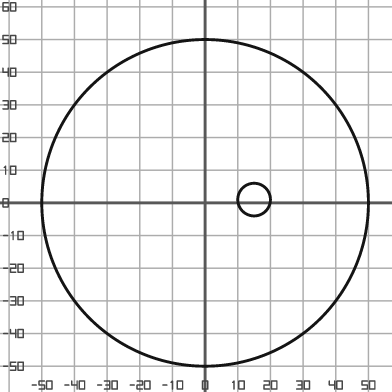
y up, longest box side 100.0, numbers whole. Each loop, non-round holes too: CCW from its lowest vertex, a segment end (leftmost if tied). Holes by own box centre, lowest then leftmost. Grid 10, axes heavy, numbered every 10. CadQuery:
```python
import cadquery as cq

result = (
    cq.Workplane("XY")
    .moveTo(0.0, 0.0)
    .circle(50.0)
    .moveTo(15.0, 1.0)
    .circle(5.0)
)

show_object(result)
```